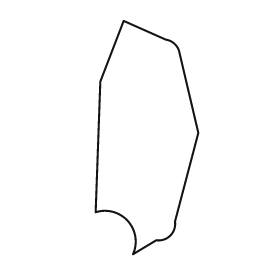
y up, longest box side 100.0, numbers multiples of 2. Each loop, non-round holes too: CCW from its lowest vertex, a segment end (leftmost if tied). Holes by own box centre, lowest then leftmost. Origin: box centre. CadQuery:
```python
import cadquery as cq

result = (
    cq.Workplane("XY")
    .moveTo(-6.0, -50.0)
    .lineTo(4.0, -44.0)
    .threePointArc((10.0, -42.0), (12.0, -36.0))
    .lineTo(22.0, 2.0)
    .lineTo(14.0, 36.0)
    .threePointArc((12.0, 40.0), (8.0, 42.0))
    .lineTo(-10.0, 50.0)
    .lineTo(-20.0, 24.0)
    .lineTo(-22.0, -32.0)
    .threePointArc((-8.0, -36.0), (-6.0, -50.0))
    .close()
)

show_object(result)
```